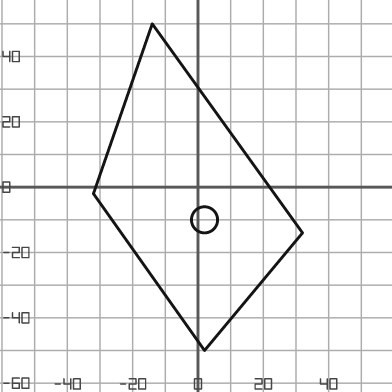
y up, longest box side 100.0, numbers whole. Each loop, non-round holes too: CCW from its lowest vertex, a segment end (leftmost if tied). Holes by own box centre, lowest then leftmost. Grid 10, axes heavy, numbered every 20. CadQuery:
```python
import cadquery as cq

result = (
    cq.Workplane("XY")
    .moveTo(2.0, -50.0)
    .lineTo(32.0, -14.0)
    .lineTo(-14.0, 50.0)
    .lineTo(-32.0, -2.0)
    .close()
    .moveTo(2.0, -10.0)
    .circle(4.0)
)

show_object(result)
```